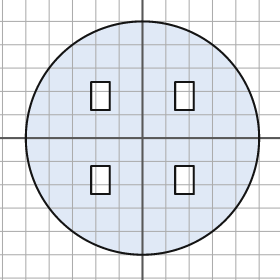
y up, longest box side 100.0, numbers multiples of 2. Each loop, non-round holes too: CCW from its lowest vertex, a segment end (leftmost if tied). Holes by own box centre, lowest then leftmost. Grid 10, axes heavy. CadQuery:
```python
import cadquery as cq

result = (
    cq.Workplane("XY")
    .moveTo(0.0, 0.0)
    .circle(50.0)
    .moveTo(-22.0, -24.0)
    .lineTo(-14.0, -24.0)
    .lineTo(-14.0, -12.0)
    .lineTo(-22.0, -12.0)
    .close()
    .moveTo(14.0, -24.0)
    .lineTo(22.0, -24.0)
    .lineTo(22.0, -12.0)
    .lineTo(14.0, -12.0)
    .close()
    .moveTo(-22.0, 12.0)
    .lineTo(-14.0, 12.0)
    .lineTo(-14.0, 24.0)
    .lineTo(-22.0, 24.0)
    .close()
    .moveTo(14.0, 12.0)
    .lineTo(22.0, 12.0)
    .lineTo(22.0, 24.0)
    .lineTo(14.0, 24.0)
    .close()
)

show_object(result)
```